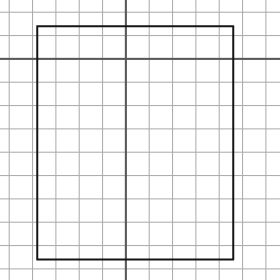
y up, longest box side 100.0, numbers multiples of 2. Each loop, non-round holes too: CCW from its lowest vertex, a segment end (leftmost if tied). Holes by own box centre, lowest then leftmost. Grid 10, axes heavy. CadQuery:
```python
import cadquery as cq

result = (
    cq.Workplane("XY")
    .moveTo(-38.0, -86.0)
    .lineTo(46.0, -86.0)
    .lineTo(46.0, 14.0)
    .lineTo(-38.0, 14.0)
    .close()
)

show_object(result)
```